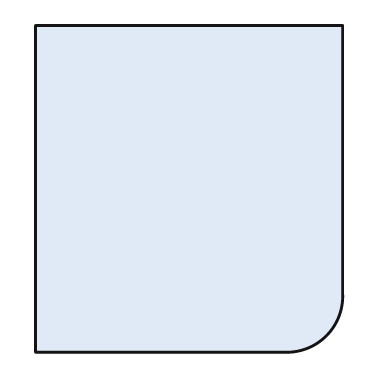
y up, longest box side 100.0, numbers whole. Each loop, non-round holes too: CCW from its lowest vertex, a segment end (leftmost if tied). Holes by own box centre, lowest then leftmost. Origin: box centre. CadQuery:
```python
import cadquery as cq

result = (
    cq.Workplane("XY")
    .moveTo(-47.0, -50.0)
    .lineTo(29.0, -50.0)
    .threePointArc((42.0, -45.0), (47.0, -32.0))
    .lineTo(47.0, 50.0)
    .lineTo(-47.0, 50.0)
    .close()
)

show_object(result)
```